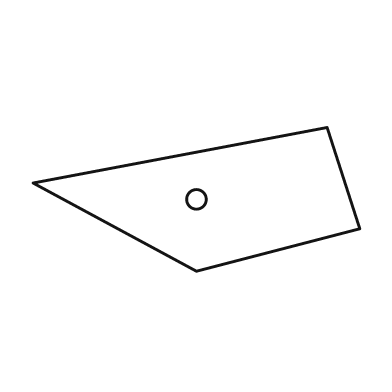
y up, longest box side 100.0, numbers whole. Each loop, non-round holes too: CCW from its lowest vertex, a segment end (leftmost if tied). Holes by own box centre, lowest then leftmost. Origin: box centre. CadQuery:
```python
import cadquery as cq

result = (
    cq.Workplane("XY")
    .moveTo(0.0, -22.0)
    .lineTo(50.0, -9.0)
    .lineTo(40.0, 22.0)
    .lineTo(-50.0, 5.0)
    .close()
    .moveTo(0.0, 0.0)
    .circle(3.0)
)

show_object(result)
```